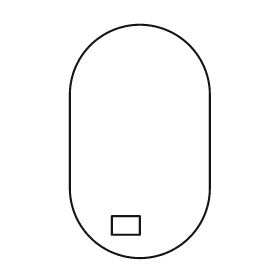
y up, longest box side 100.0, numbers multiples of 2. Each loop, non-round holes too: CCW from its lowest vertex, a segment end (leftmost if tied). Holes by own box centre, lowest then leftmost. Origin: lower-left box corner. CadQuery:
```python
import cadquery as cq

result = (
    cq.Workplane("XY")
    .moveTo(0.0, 30.0)
    .threePointArc((30.0, 0.0), (60.0, 30.0))
    .lineTo(60.0, 70.0)
    .threePointArc((30.0, 100.0), (0.0, 70.0))
    .close()
    .moveTo(18.0, 10.0)
    .lineTo(30.0, 10.0)
    .lineTo(30.0, 18.0)
    .lineTo(18.0, 18.0)
    .close()
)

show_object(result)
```